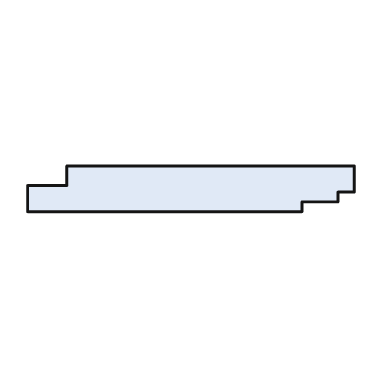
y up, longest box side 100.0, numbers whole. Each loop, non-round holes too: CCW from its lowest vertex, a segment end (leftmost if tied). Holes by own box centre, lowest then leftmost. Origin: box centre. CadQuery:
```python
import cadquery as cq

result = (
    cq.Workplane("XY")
    .moveTo(-50.0, -7.0)
    .lineTo(34.0, -7.0)
    .lineTo(34.0, -4.0)
    .lineTo(45.0, -4.0)
    .lineTo(45.0, -1.0)
    .lineTo(50.0, -1.0)
    .lineTo(50.0, 7.0)
    .lineTo(-38.0, 7.0)
    .lineTo(-38.0, 1.0)
    .lineTo(-50.0, 1.0)
    .close()
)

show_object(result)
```